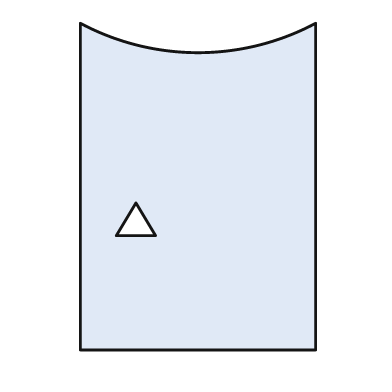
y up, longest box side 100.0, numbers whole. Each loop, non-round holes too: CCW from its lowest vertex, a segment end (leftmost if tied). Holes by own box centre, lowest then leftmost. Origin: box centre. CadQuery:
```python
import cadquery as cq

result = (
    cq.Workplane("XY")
    .moveTo(-36.0, -50.0)
    .lineTo(36.0, -50.0)
    .lineTo(36.0, 50.0)
    .threePointArc((0.0, 41.0), (-36.0, 50.0))
    .close()
    .moveTo(-25.0, -15.0)
    .lineTo(-13.0, -15.0)
    .lineTo(-19.0, -5.0)
    .close()
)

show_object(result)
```